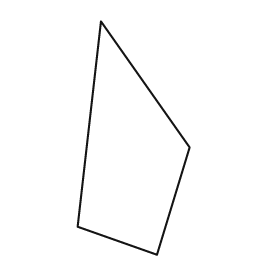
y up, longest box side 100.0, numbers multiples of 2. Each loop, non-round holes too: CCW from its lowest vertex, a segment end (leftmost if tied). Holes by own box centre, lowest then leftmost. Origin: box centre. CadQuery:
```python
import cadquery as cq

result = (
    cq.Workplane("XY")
    .moveTo(10.0, -50.0)
    .lineTo(24.0, -4.0)
    .lineTo(-14.0, 50.0)
    .lineTo(-24.0, -38.0)
    .close()
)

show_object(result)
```